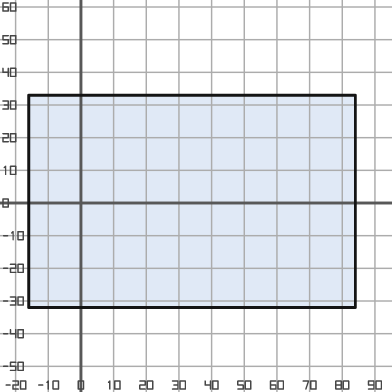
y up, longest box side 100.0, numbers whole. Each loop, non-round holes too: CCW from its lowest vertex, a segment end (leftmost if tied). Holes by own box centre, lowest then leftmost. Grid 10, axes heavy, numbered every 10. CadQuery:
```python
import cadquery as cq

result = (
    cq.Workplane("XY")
    .moveTo(-16.0, -32.0)
    .lineTo(84.0, -32.0)
    .lineTo(84.0, 33.0)
    .lineTo(-16.0, 33.0)
    .close()
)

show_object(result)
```